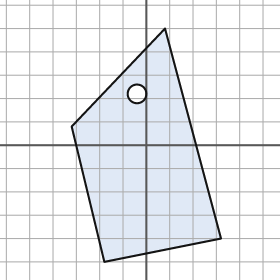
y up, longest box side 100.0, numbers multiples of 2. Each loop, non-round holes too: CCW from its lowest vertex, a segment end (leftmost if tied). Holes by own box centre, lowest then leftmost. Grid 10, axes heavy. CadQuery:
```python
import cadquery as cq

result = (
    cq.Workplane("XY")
    .moveTo(-18.0, -50.0)
    .lineTo(32.0, -40.0)
    .lineTo(8.0, 50.0)
    .lineTo(-32.0, 8.0)
    .close()
    .moveTo(-4.0, 22.0)
    .circle(4.0)
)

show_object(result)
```